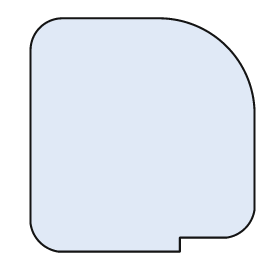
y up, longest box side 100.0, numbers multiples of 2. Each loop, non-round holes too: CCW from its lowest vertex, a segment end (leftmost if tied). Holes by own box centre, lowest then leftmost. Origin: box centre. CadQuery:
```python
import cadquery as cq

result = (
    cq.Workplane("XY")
    .moveTo(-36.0, -50.0)
    .lineTo(16.0, -50.0)
    .lineTo(16.0, -44.0)
    .lineTo(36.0, -44.0)
    .threePointArc((44.0, -40.0), (48.0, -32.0))
    .lineTo(48.0, 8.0)
    .threePointArc((36.0, 38.0), (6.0, 50.0))
    .lineTo(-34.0, 50.0)
    .threePointArc((-44.0, 46.0), (-48.0, 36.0))
    .lineTo(-48.0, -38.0)
    .threePointArc((-44.0, -46.0), (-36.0, -50.0))
    .close()
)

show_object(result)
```